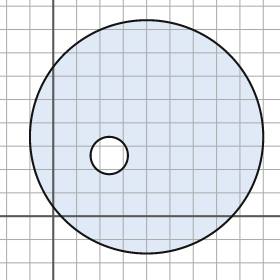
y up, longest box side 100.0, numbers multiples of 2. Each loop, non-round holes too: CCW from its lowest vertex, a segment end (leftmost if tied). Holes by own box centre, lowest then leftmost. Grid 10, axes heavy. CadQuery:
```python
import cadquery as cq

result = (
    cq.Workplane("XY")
    .moveTo(40.0, 34.0)
    .circle(50.0)
    .moveTo(24.0, 26.0)
    .circle(8.0)
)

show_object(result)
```